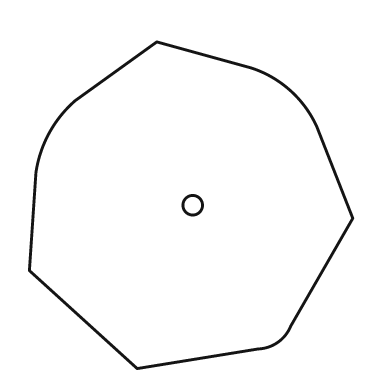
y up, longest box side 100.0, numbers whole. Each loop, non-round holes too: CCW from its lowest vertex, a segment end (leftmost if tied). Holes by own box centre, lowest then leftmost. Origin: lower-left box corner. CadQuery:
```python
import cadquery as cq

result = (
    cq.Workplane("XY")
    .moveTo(33.0, 0.0)
    .lineTo(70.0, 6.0)
    .threePointArc((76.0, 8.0), (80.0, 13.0))
    .lineTo(99.0, 46.0)
    .lineTo(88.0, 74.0)
    .threePointArc((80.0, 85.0), (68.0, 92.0))
    .lineTo(39.0, 100.0)
    .lineTo(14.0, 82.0)
    .threePointArc((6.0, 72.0), (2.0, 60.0))
    .lineTo(0.0, 30.0)
    .close()
    .moveTo(50.0, 50.0)
    .circle(3.0)
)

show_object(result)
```